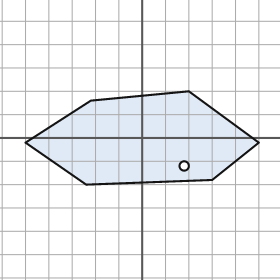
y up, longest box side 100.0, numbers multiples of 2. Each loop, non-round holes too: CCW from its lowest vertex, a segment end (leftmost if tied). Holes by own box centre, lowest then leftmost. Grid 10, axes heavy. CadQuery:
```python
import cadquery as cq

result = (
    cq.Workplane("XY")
    .moveTo(-24.0, -20.0)
    .lineTo(30.0, -18.0)
    .lineTo(50.0, -2.0)
    .lineTo(20.0, 20.0)
    .lineTo(-22.0, 16.0)
    .lineTo(-50.0, -2.0)
    .close()
    .moveTo(18.0, -12.0)
    .circle(2.0)
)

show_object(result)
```